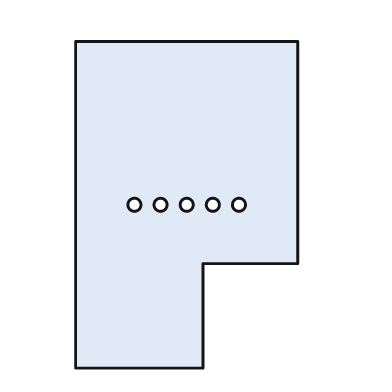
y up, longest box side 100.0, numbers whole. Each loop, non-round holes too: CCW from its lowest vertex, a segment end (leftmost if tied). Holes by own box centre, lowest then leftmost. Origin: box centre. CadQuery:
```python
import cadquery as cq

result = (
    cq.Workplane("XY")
    .moveTo(-34.0, -50.0)
    .lineTo(5.0, -50.0)
    .lineTo(5.0, -18.0)
    .lineTo(34.0, -18.0)
    .lineTo(34.0, 50.0)
    .lineTo(-34.0, 50.0)
    .close()
    .moveTo(-16.0, 0.0)
    .circle(2.0)
    .moveTo(-8.0, 0.0)
    .circle(2.0)
    .moveTo(0.0, 0.0)
    .circle(2.0)
    .moveTo(8.0, 0.0)
    .circle(2.0)
    .moveTo(16.0, 0.0)
    .circle(2.0)
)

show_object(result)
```